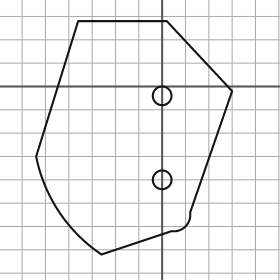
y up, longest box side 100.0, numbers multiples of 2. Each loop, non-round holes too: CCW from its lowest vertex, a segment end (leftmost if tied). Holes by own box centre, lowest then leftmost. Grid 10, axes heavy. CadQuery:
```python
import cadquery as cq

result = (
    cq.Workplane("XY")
    .moveTo(-26.0, -72.0)
    .lineTo(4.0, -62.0)
    .threePointArc((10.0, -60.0), (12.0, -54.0))
    .lineTo(30.0, -2.0)
    .lineTo(2.0, 28.0)
    .lineTo(-36.0, 28.0)
    .lineTo(-54.0, -30.0)
    .threePointArc((-44.0, -54.0), (-26.0, -72.0))
    .close()
    .moveTo(0.0, -40.0)
    .circle(4.0)
    .moveTo(0.0, -4.0)
    .circle(4.0)
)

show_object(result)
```